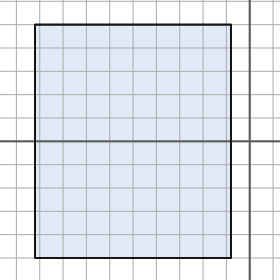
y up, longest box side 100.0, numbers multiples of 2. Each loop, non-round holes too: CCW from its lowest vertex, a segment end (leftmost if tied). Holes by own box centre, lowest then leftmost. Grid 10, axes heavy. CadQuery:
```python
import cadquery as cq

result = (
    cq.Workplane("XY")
    .moveTo(-92.0, -50.0)
    .lineTo(-8.0, -50.0)
    .lineTo(-8.0, 50.0)
    .lineTo(-92.0, 50.0)
    .close()
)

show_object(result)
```